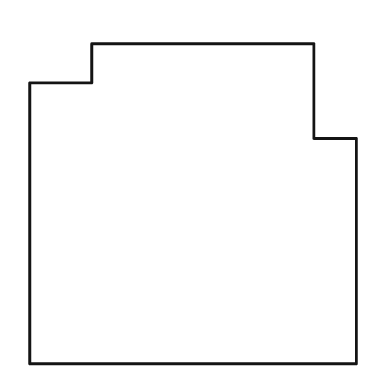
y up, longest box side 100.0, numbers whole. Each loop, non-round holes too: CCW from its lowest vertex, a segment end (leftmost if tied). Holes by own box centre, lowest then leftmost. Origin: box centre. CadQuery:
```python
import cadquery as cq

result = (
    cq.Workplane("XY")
    .moveTo(-50.0, -49.0)
    .lineTo(50.0, -49.0)
    .lineTo(50.0, 20.0)
    .lineTo(37.0, 20.0)
    .lineTo(37.0, 49.0)
    .lineTo(-31.0, 49.0)
    .lineTo(-31.0, 37.0)
    .lineTo(-50.0, 37.0)
    .close()
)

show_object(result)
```